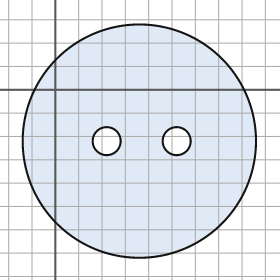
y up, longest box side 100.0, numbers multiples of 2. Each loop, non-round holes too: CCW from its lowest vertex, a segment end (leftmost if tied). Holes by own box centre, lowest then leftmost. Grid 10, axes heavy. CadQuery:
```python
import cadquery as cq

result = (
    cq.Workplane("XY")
    .moveTo(36.0, -22.0)
    .circle(50.0)
    .moveTo(22.0, -22.0)
    .circle(6.0)
    .moveTo(52.0, -22.0)
    .circle(6.0)
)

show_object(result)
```